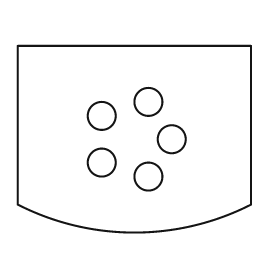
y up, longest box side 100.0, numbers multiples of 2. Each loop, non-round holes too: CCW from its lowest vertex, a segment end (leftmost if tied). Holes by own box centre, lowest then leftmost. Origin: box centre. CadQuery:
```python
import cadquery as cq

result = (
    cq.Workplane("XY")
    .moveTo(-50.0, -28.0)
    .threePointArc((0.0, -40.0), (50.0, -28.0))
    .lineTo(50.0, 40.0)
    .lineTo(-50.0, 40.0)
    .close()
    .moveTo(6.0, -16.0)
    .circle(6.0)
    .moveTo(-14.0, -10.0)
    .circle(6.0)
    .moveTo(16.0, 0.0)
    .circle(6.0)
    .moveTo(-14.0, 10.0)
    .circle(6.0)
    .moveTo(6.0, 16.0)
    .circle(6.0)
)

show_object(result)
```